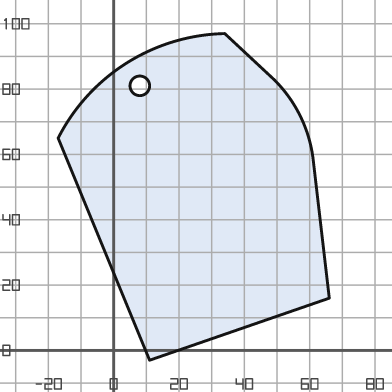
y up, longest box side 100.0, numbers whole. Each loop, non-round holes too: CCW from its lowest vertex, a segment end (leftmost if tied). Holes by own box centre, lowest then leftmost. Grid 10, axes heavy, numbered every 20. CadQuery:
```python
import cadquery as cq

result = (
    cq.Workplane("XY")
    .moveTo(11.0, -3.0)
    .lineTo(66.0, 16.0)
    .lineTo(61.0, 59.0)
    .threePointArc((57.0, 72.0), (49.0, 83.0))
    .lineTo(34.0, 97.0)
    .threePointArc((4.0, 88.0), (-17.0, 65.0))
    .close()
    .moveTo(8.0, 81.0)
    .circle(3.0)
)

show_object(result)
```